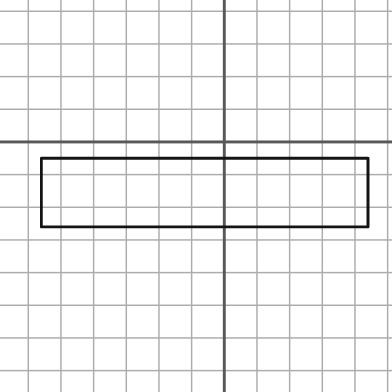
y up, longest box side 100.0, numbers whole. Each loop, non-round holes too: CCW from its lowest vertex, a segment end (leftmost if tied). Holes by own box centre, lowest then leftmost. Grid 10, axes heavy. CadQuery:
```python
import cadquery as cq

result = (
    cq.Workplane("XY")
    .moveTo(-56.0, -26.0)
    .lineTo(44.0, -26.0)
    .lineTo(44.0, -5.0)
    .lineTo(-56.0, -5.0)
    .close()
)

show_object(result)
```